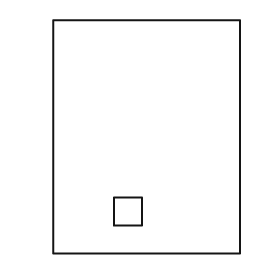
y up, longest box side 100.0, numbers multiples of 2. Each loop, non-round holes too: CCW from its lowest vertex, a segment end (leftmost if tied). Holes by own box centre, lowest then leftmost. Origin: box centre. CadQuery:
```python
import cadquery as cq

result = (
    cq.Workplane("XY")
    .moveTo(-40.0, -50.0)
    .lineTo(40.0, -50.0)
    .lineTo(40.0, 50.0)
    .lineTo(-40.0, 50.0)
    .close()
    .moveTo(-14.0, -38.0)
    .lineTo(-2.0, -38.0)
    .lineTo(-2.0, -26.0)
    .lineTo(-14.0, -26.0)
    .close()
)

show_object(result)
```